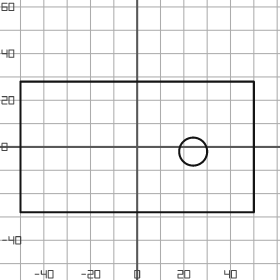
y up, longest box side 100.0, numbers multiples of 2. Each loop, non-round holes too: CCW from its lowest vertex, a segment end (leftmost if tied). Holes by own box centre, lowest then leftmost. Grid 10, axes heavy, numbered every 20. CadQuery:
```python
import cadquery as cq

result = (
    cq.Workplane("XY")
    .moveTo(-50.0, -28.0)
    .lineTo(50.0, -28.0)
    .lineTo(50.0, 28.0)
    .lineTo(-50.0, 28.0)
    .close()
    .moveTo(24.0, -2.0)
    .circle(6.0)
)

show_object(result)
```